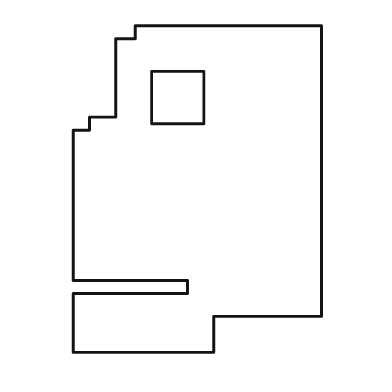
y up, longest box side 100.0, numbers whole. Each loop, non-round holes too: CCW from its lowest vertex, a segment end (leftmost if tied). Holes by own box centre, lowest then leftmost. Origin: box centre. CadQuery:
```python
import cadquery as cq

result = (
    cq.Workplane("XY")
    .moveTo(-38.0, -50.0)
    .lineTo(5.0, -50.0)
    .lineTo(5.0, -39.0)
    .lineTo(38.0, -39.0)
    .lineTo(38.0, 50.0)
    .lineTo(-19.0, 50.0)
    .lineTo(-19.0, 46.0)
    .lineTo(-25.0, 46.0)
    .lineTo(-25.0, 22.0)
    .lineTo(-33.0, 22.0)
    .lineTo(-33.0, 18.0)
    .lineTo(-38.0, 18.0)
    .lineTo(-38.0, -28.0)
    .lineTo(-3.0, -28.0)
    .lineTo(-3.0, -32.0)
    .lineTo(-38.0, -32.0)
    .close()
    .moveTo(-14.0, 20.0)
    .lineTo(2.0, 20.0)
    .lineTo(2.0, 36.0)
    .lineTo(-14.0, 36.0)
    .close()
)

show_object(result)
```